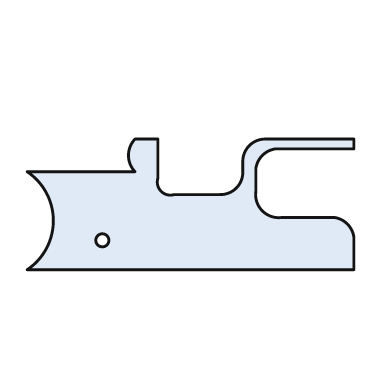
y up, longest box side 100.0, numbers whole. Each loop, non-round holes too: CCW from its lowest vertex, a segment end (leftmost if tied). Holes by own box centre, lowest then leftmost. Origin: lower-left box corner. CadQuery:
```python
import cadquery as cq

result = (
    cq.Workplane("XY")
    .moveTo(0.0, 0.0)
    .lineTo(100.0, 0.0)
    .lineTo(100.0, 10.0)
    .threePointArc((98.0, 14.0), (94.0, 16.0))
    .lineTo(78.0, 16.0)
    .threePointArc((72.0, 18.0), (70.0, 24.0))
    .lineTo(70.0, 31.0)
    .threePointArc((72.0, 35.0), (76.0, 37.0))
    .lineTo(100.0, 37.0)
    .lineTo(100.0, 40.0)
    .lineTo(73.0, 40.0)
    .threePointArc((68.0, 38.0), (66.0, 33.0))
    .lineTo(66.0, 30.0)
    .threePointArc((64.0, 25.0), (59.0, 23.0))
    .lineTo(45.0, 23.0)
    .threePointArc((41.0, 24.0), (40.0, 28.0))
    .lineTo(40.0, 40.0)
    .lineTo(33.0, 40.0)
    .threePointArc((31.0, 35.0), (33.0, 30.0))
    .lineTo(0.0, 30.0)
    .threePointArc((8.0, 15.0), (0.0, 0.0))
    .close()
    .moveTo(23.0, 9.0)
    .circle(2.0)
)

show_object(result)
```